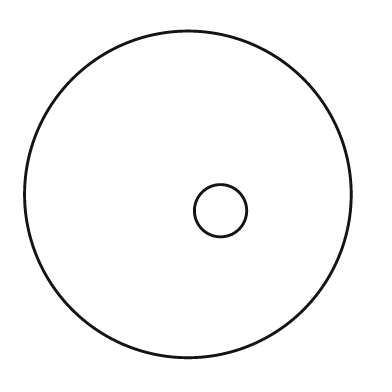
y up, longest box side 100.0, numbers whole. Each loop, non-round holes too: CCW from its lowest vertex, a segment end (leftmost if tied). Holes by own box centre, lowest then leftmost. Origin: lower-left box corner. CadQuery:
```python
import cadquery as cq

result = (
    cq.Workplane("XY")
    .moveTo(50.0, 50.0)
    .circle(50.0)
    .moveTo(60.0, 45.0)
    .circle(8.0)
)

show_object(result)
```